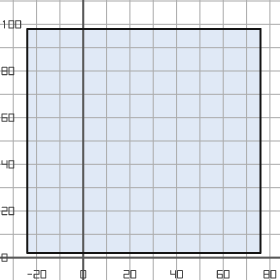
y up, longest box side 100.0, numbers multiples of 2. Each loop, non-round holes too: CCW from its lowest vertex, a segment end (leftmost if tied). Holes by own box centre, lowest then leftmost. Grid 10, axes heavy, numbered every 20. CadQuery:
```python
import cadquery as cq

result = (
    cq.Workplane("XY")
    .moveTo(-24.0, 2.0)
    .lineTo(76.0, 2.0)
    .lineTo(76.0, 98.0)
    .lineTo(-24.0, 98.0)
    .close()
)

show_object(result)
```